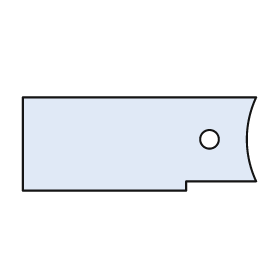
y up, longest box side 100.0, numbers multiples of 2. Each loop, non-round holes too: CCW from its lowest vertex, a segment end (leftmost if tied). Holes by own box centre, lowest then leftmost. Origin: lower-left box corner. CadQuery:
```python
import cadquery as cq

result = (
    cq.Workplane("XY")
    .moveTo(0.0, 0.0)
    .lineTo(70.0, 0.0)
    .lineTo(70.0, 4.0)
    .lineTo(100.0, 4.0)
    .threePointArc((96.0, 22.0), (100.0, 40.0))
    .lineTo(0.0, 40.0)
    .close()
    .moveTo(80.0, 22.0)
    .circle(4.0)
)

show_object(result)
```